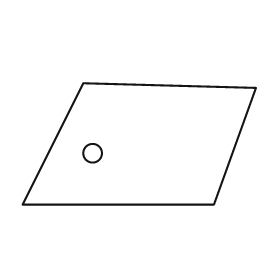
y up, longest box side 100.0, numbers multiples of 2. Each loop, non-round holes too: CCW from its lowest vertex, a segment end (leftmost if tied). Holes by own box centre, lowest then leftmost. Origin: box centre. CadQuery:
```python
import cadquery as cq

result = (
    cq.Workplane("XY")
    .moveTo(-50.0, -26.0)
    .lineTo(32.0, -26.0)
    .lineTo(50.0, 24.0)
    .lineTo(-24.0, 26.0)
    .close()
    .moveTo(-20.0, -4.0)
    .circle(4.0)
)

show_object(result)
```